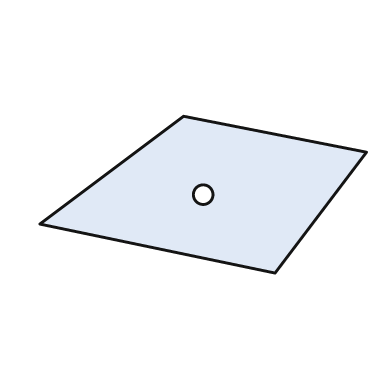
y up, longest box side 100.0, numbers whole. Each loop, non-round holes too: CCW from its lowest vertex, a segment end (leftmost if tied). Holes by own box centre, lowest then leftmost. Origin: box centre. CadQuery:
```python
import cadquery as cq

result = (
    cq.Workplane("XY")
    .moveTo(22.0, -24.0)
    .lineTo(50.0, 13.0)
    .lineTo(-6.0, 24.0)
    .lineTo(-50.0, -9.0)
    .close()
    .moveTo(0.0, 0.0)
    .circle(3.0)
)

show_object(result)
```